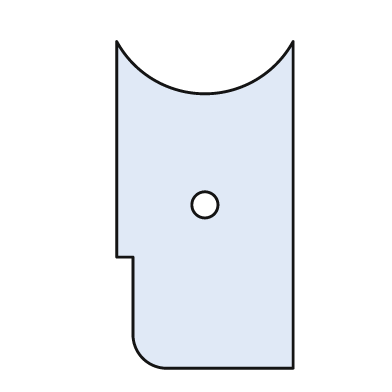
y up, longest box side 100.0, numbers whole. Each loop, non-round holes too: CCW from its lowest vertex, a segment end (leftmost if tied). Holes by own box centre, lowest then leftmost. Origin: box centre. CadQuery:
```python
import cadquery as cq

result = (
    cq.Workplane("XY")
    .moveTo(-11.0, -50.0)
    .lineTo(27.0, -50.0)
    .lineTo(27.0, 50.0)
    .threePointArc((0.0, 34.0), (-27.0, 50.0))
    .lineTo(-27.0, -16.0)
    .lineTo(-22.0, -16.0)
    .lineTo(-22.0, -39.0)
    .threePointArc((-19.0, -47.0), (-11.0, -50.0))
    .close()
    .moveTo(0.0, 0.0)
    .circle(4.0)
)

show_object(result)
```